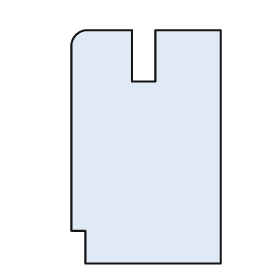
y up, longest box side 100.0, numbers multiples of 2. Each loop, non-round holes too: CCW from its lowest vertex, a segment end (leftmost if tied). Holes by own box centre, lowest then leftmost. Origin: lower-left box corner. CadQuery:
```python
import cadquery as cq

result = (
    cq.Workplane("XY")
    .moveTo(6.0, 0.0)
    .lineTo(64.0, 0.0)
    .lineTo(64.0, 100.0)
    .lineTo(36.0, 100.0)
    .lineTo(36.0, 78.0)
    .lineTo(26.0, 78.0)
    .lineTo(26.0, 100.0)
    .lineTo(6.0, 100.0)
    .threePointArc((2.0, 98.0), (0.0, 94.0))
    .lineTo(0.0, 14.0)
    .lineTo(6.0, 14.0)
    .close()
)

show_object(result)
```